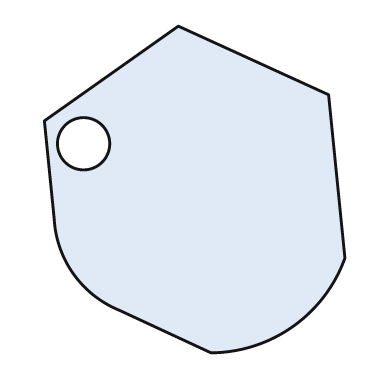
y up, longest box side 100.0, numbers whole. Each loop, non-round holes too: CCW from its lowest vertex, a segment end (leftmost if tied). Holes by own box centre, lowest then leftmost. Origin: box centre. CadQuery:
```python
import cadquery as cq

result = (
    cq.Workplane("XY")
    .moveTo(5.0, -50.0)
    .threePointArc((30.0, -42.0), (46.0, -21.0))
    .lineTo(41.0, 29.0)
    .lineTo(-5.0, 50.0)
    .lineTo(-46.0, 21.0)
    .lineTo(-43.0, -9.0)
    .threePointArc((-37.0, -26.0), (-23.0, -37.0))
    .close()
    .moveTo(-34.0, 14.0)
    .circle(8.0)
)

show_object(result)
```